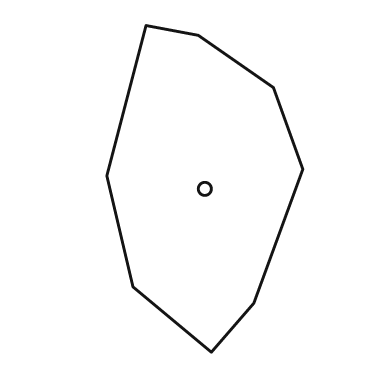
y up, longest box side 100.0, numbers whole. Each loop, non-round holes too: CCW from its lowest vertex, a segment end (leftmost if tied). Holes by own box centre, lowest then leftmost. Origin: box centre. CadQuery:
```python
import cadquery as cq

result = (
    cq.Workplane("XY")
    .moveTo(2.0, -50.0)
    .lineTo(15.0, -35.0)
    .lineTo(30.0, 6.0)
    .lineTo(21.0, 31.0)
    .lineTo(-2.0, 47.0)
    .lineTo(-18.0, 50.0)
    .lineTo(-30.0, 4.0)
    .lineTo(-22.0, -30.0)
    .close()
    .moveTo(0.0, 0.0)
    .circle(2.0)
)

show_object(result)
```